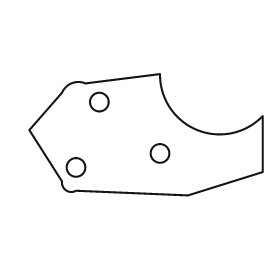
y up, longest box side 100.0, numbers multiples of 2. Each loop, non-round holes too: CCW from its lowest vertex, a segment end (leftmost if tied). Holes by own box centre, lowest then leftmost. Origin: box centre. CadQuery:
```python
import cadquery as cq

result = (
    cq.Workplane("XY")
    .moveTo(18.0, -26.0)
    .lineTo(50.0, -16.0)
    .lineTo(50.0, 8.0)
    .threePointArc((22.0, 2.0), (6.0, 26.0))
    .lineTo(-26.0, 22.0)
    .threePointArc((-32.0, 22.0), (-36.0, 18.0))
    .lineTo(-50.0, 2.0)
    .lineTo(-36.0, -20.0)
    .threePointArc((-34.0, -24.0), (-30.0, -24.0))
    .close()
    .moveTo(-30.0, -14.0)
    .circle(4.0)
    .moveTo(6.0, -8.0)
    .circle(4.0)
    .moveTo(-20.0, 14.0)
    .circle(4.0)
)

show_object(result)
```